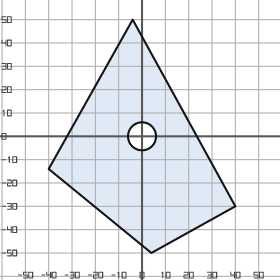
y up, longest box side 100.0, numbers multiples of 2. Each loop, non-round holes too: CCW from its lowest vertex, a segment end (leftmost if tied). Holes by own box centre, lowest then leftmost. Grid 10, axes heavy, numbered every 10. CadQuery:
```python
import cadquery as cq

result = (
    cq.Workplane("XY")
    .moveTo(4.0, -50.0)
    .lineTo(40.0, -30.0)
    .lineTo(-4.0, 50.0)
    .lineTo(-40.0, -14.0)
    .close()
    .moveTo(0.0, 0.0)
    .circle(6.0)
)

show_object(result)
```